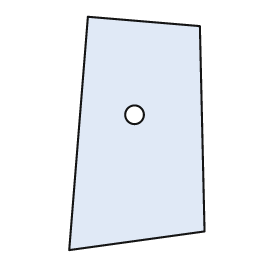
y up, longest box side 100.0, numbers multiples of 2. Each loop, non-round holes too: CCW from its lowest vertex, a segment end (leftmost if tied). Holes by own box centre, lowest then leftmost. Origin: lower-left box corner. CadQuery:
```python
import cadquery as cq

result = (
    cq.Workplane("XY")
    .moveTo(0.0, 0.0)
    .lineTo(58.0, 8.0)
    .lineTo(56.0, 96.0)
    .lineTo(8.0, 100.0)
    .close()
    .moveTo(28.0, 58.0)
    .circle(4.0)
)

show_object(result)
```